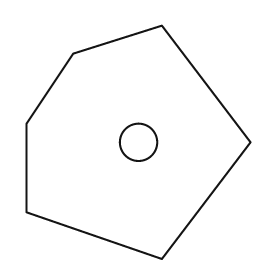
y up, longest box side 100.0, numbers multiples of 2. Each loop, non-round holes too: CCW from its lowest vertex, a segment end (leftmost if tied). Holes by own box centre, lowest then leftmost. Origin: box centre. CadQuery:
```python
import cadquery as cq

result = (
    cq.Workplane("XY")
    .moveTo(10.0, -50.0)
    .lineTo(48.0, 0.0)
    .lineTo(10.0, 50.0)
    .lineTo(-28.0, 38.0)
    .lineTo(-48.0, 8.0)
    .lineTo(-48.0, -30.0)
    .close()
    .moveTo(0.0, 0.0)
    .circle(8.0)
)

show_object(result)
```